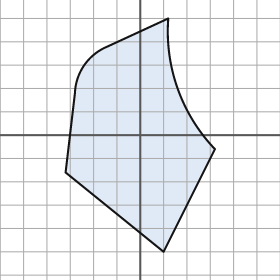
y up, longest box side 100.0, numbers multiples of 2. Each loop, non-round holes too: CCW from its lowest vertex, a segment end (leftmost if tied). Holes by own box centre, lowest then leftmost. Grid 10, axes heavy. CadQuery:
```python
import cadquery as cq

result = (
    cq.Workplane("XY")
    .moveTo(10.0, -50.0)
    .lineTo(32.0, -6.0)
    .threePointArc((16.0, 20.0), (12.0, 50.0))
    .lineTo(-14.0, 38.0)
    .threePointArc((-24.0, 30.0), (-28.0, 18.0))
    .lineTo(-32.0, -16.0)
    .close()
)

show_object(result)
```